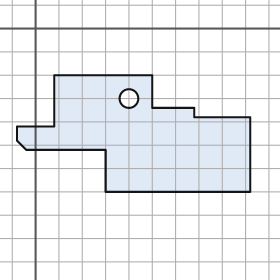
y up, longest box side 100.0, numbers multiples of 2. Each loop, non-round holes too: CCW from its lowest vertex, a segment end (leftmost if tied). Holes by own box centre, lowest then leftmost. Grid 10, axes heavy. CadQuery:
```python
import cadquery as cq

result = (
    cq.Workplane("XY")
    .moveTo(30.0, -70.0)
    .lineTo(92.0, -70.0)
    .lineTo(92.0, -38.0)
    .lineTo(68.0, -38.0)
    .lineTo(68.0, -34.0)
    .lineTo(50.0, -34.0)
    .lineTo(50.0, -20.0)
    .lineTo(8.0, -20.0)
    .lineTo(8.0, -42.0)
    .lineTo(-8.0, -42.0)
    .lineTo(-8.0, -48.0)
    .lineTo(-4.0, -52.0)
    .lineTo(30.0, -52.0)
    .close()
    .moveTo(40.0, -30.0)
    .circle(4.0)
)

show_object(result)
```